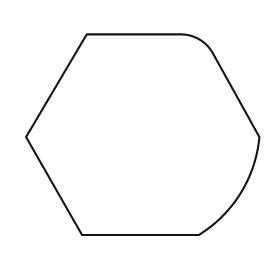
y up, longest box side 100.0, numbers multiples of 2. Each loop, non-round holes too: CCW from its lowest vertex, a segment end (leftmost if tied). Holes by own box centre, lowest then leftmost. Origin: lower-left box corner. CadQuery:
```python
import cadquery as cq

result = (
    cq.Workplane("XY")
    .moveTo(24.0, 0.0)
    .lineTo(74.0, 0.0)
    .threePointArc((92.0, 18.0), (100.0, 42.0))
    .lineTo(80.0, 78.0)
    .threePointArc((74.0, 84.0), (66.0, 86.0))
    .lineTo(26.0, 86.0)
    .lineTo(0.0, 42.0)
    .close()
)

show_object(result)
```